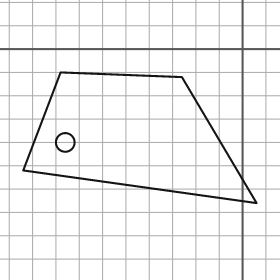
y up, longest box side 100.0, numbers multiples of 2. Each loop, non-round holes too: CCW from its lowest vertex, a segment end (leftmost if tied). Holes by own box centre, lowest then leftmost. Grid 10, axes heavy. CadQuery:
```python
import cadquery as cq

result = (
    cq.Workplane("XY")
    .moveTo(6.0, -66.0)
    .lineTo(-26.0, -12.0)
    .lineTo(-78.0, -10.0)
    .lineTo(-94.0, -52.0)
    .close()
    .moveTo(-76.0, -40.0)
    .circle(4.0)
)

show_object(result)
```